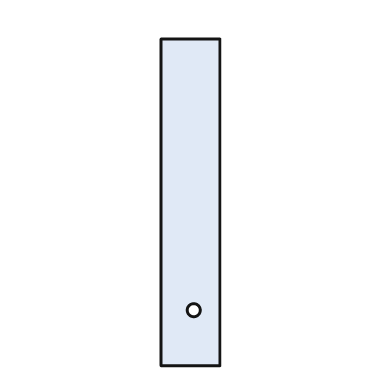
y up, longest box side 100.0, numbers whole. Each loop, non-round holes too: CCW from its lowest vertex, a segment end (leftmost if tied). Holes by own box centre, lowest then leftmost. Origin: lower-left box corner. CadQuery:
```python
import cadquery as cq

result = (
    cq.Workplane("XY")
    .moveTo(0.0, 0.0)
    .lineTo(18.0, 0.0)
    .lineTo(18.0, 100.0)
    .lineTo(0.0, 100.0)
    .close()
    .moveTo(10.0, 17.0)
    .circle(2.0)
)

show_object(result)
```